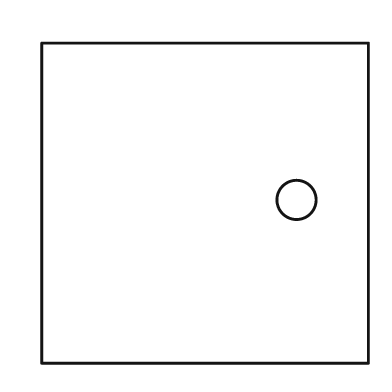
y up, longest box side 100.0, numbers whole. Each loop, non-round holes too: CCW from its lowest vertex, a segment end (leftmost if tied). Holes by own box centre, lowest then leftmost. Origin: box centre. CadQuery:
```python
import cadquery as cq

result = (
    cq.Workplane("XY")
    .moveTo(-50.0, -49.0)
    .lineTo(50.0, -49.0)
    .lineTo(50.0, 49.0)
    .lineTo(-50.0, 49.0)
    .close()
    .moveTo(28.0, 1.0)
    .circle(6.0)
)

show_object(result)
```